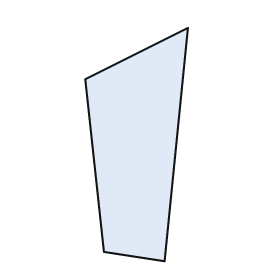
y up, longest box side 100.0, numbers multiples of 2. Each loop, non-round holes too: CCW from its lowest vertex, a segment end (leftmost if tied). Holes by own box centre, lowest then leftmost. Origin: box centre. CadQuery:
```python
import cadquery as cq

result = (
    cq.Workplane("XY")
    .moveTo(12.0, -50.0)
    .lineTo(22.0, 50.0)
    .lineTo(-22.0, 28.0)
    .lineTo(-14.0, -46.0)
    .close()
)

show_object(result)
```